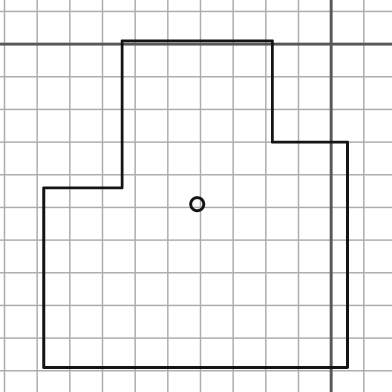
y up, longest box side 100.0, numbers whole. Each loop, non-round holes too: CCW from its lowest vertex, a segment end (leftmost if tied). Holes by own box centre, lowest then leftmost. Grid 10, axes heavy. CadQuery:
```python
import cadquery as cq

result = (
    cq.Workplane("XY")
    .moveTo(-88.0, -99.0)
    .lineTo(5.0, -99.0)
    .lineTo(5.0, -30.0)
    .lineTo(-18.0, -30.0)
    .lineTo(-18.0, 1.0)
    .lineTo(-64.0, 1.0)
    .lineTo(-64.0, -44.0)
    .lineTo(-88.0, -44.0)
    .close()
    .moveTo(-41.0, -49.0)
    .circle(2.0)
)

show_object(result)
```